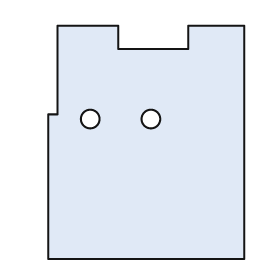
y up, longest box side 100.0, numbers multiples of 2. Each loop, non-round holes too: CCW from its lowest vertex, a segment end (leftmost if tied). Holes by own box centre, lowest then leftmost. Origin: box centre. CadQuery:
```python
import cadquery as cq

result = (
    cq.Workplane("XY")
    .moveTo(-42.0, -50.0)
    .lineTo(42.0, -50.0)
    .lineTo(42.0, 50.0)
    .lineTo(18.0, 50.0)
    .lineTo(18.0, 40.0)
    .lineTo(-12.0, 40.0)
    .lineTo(-12.0, 50.0)
    .lineTo(-38.0, 50.0)
    .lineTo(-38.0, 12.0)
    .lineTo(-42.0, 12.0)
    .close()
    .moveTo(-24.0, 10.0)
    .circle(4.0)
    .moveTo(2.0, 10.0)
    .circle(4.0)
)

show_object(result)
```